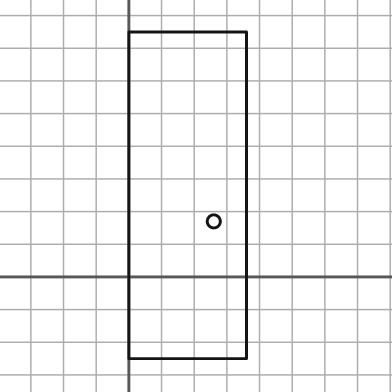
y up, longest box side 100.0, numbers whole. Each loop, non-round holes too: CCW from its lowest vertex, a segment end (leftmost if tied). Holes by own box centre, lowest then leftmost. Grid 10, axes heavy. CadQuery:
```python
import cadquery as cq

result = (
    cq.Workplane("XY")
    .moveTo(0.0, -25.0)
    .lineTo(36.0, -25.0)
    .lineTo(36.0, 75.0)
    .lineTo(0.0, 75.0)
    .close()
    .moveTo(26.0, 17.0)
    .circle(2.0)
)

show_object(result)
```